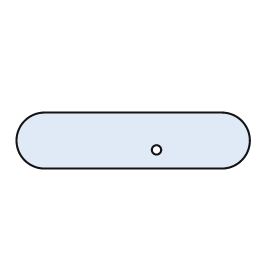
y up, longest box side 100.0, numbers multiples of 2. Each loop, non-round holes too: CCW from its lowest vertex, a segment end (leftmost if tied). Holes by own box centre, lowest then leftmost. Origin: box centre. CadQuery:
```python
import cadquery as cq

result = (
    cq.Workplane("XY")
    .moveTo(-38.0, -12.0)
    .lineTo(38.0, -12.0)
    .threePointArc((50.0, 0.0), (38.0, 12.0))
    .lineTo(-38.0, 12.0)
    .threePointArc((-50.0, 0.0), (-38.0, -12.0))
    .close()
    .moveTo(10.0, -4.0)
    .circle(2.0)
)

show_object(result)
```